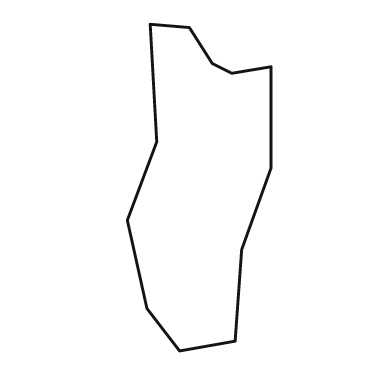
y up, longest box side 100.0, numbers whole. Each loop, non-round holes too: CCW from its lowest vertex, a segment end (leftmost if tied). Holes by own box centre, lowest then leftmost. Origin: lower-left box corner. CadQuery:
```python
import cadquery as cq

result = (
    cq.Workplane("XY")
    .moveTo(16.0, 0.0)
    .lineTo(33.0, 3.0)
    .lineTo(35.0, 31.0)
    .lineTo(44.0, 56.0)
    .lineTo(44.0, 87.0)
    .lineTo(32.0, 85.0)
    .lineTo(26.0, 88.0)
    .lineTo(19.0, 99.0)
    .lineTo(7.0, 100.0)
    .lineTo(9.0, 64.0)
    .lineTo(0.0, 40.0)
    .lineTo(6.0, 13.0)
    .close()
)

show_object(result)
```